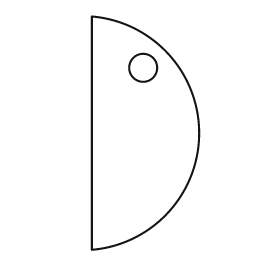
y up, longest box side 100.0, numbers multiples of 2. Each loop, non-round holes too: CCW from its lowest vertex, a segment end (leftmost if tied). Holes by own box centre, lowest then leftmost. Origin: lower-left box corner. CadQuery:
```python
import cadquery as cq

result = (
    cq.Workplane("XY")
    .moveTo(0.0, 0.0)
    .threePointArc((46.0, 50.0), (0.0, 100.0))
    .close()
    .moveTo(22.0, 78.0)
    .circle(6.0)
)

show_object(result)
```